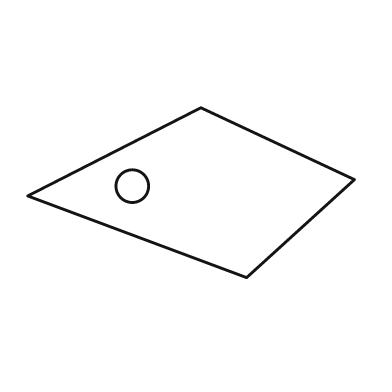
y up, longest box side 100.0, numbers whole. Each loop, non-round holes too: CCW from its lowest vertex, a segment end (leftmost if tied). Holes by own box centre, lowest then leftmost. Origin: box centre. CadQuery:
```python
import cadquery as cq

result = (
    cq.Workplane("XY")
    .moveTo(17.0, -26.0)
    .lineTo(50.0, 4.0)
    .lineTo(3.0, 26.0)
    .lineTo(-50.0, -1.0)
    .close()
    .moveTo(-18.0, 2.0)
    .circle(5.0)
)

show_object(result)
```